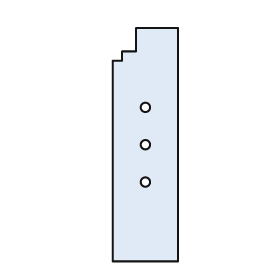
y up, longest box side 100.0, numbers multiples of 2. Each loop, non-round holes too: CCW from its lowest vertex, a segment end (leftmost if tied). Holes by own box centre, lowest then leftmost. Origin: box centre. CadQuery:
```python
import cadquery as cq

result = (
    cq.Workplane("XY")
    .moveTo(-14.0, -50.0)
    .lineTo(14.0, -50.0)
    .lineTo(14.0, 50.0)
    .lineTo(-4.0, 50.0)
    .lineTo(-4.0, 40.0)
    .lineTo(-10.0, 40.0)
    .lineTo(-10.0, 36.0)
    .lineTo(-14.0, 36.0)
    .close()
    .moveTo(0.0, -16.0)
    .circle(2.0)
    .moveTo(0.0, 0.0)
    .circle(2.0)
    .moveTo(0.0, 16.0)
    .circle(2.0)
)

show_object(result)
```